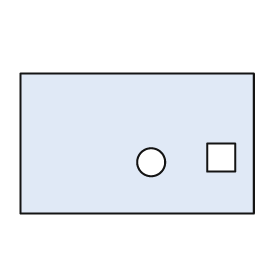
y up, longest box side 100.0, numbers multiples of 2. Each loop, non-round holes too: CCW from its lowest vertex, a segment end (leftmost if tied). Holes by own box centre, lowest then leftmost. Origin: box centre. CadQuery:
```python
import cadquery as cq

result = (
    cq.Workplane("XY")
    .moveTo(-50.0, -30.0)
    .lineTo(50.0, -30.0)
    .lineTo(50.0, 30.0)
    .lineTo(-50.0, 30.0)
    .close()
    .moveTo(6.0, -8.0)
    .circle(6.0)
    .moveTo(30.0, -12.0)
    .lineTo(42.0, -12.0)
    .lineTo(42.0, 0.0)
    .lineTo(30.0, 0.0)
    .close()
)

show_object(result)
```